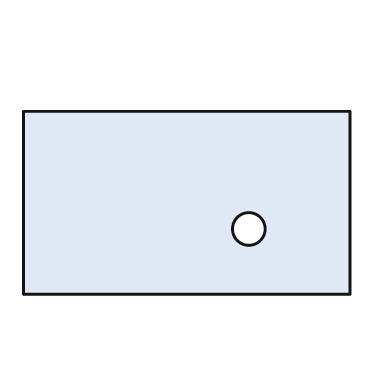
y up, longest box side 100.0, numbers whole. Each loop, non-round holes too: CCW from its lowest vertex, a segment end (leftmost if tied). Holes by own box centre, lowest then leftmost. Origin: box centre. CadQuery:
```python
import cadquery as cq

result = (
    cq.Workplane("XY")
    .moveTo(-50.0, -28.0)
    .lineTo(50.0, -28.0)
    .lineTo(50.0, 28.0)
    .lineTo(-50.0, 28.0)
    .close()
    .moveTo(19.0, -8.0)
    .circle(5.0)
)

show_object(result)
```